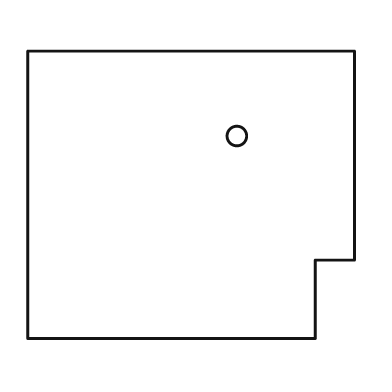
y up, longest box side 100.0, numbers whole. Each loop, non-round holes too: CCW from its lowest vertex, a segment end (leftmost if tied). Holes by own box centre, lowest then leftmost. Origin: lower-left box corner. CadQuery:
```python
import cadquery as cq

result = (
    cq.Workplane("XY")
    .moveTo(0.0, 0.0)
    .lineTo(88.0, 0.0)
    .lineTo(88.0, 24.0)
    .lineTo(100.0, 24.0)
    .lineTo(100.0, 88.0)
    .lineTo(0.0, 88.0)
    .close()
    .moveTo(64.0, 62.0)
    .circle(3.0)
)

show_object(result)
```